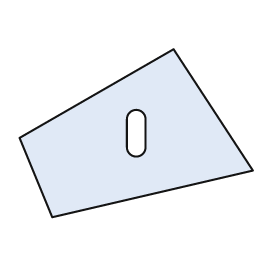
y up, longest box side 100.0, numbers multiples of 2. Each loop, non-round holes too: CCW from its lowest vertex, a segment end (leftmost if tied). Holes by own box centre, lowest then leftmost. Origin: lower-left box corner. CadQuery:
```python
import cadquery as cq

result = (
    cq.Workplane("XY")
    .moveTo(14.0, 0.0)
    .lineTo(100.0, 20.0)
    .lineTo(66.0, 72.0)
    .lineTo(0.0, 34.0)
    .close()
    .moveTo(46.0, 30.0)
    .threePointArc((50.0, 26.0), (54.0, 30.0))
    .lineTo(54.0, 42.0)
    .threePointArc((50.0, 46.0), (46.0, 42.0))
    .close()
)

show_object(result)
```